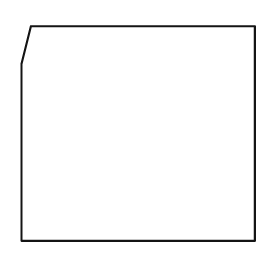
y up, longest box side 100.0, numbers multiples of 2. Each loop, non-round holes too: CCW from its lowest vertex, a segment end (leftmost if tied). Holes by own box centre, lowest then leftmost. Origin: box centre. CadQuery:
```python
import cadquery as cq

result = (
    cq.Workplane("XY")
    .moveTo(-50.0, -46.0)
    .lineTo(50.0, -46.0)
    .lineTo(50.0, 46.0)
    .lineTo(-46.0, 46.0)
    .lineTo(-50.0, 30.0)
    .close()
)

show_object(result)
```